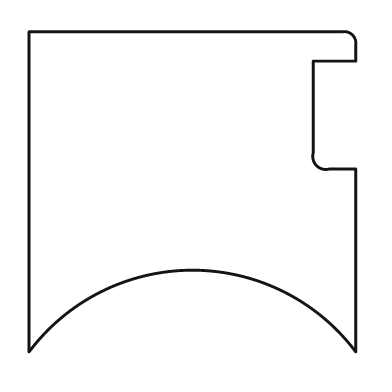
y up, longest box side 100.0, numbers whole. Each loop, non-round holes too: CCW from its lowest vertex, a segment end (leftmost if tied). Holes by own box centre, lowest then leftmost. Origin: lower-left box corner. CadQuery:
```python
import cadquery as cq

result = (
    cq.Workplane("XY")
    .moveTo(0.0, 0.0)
    .threePointArc((50.0, 25.0), (100.0, 0.0))
    .lineTo(100.0, 56.0)
    .lineTo(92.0, 56.0)
    .threePointArc((88.0, 57.0), (87.0, 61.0))
    .lineTo(87.0, 89.0)
    .lineTo(100.0, 89.0)
    .lineTo(100.0, 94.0)
    .threePointArc((99.0, 97.0), (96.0, 98.0))
    .lineTo(0.0, 98.0)
    .close()
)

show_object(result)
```